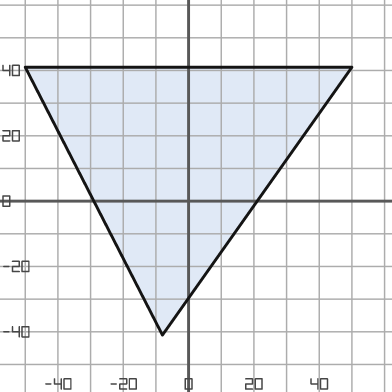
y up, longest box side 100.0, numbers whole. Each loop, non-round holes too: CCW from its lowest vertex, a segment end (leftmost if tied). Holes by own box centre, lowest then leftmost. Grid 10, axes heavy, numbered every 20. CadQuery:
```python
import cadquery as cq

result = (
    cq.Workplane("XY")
    .moveTo(-8.0, -41.0)
    .lineTo(50.0, 41.0)
    .lineTo(-50.0, 41.0)
    .close()
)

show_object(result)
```